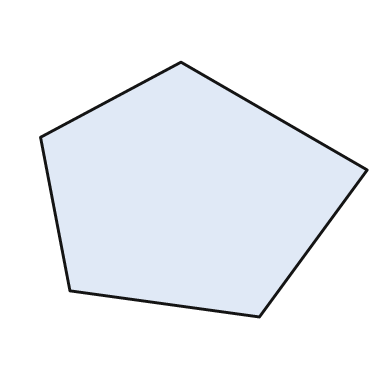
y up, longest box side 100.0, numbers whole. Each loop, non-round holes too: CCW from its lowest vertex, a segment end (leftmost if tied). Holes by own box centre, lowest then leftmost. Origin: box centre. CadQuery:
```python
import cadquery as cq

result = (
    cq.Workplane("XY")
    .moveTo(17.0, -39.0)
    .lineTo(50.0, 6.0)
    .lineTo(-7.0, 39.0)
    .lineTo(-50.0, 16.0)
    .lineTo(-41.0, -31.0)
    .close()
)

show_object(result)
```